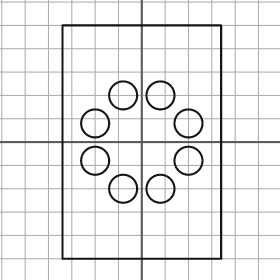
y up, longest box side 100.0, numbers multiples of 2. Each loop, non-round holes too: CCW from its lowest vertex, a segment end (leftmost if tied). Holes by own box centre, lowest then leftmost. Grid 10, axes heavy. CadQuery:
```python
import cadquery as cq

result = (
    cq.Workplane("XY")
    .moveTo(-34.0, -50.0)
    .lineTo(34.0, -50.0)
    .lineTo(34.0, 50.0)
    .lineTo(-34.0, 50.0)
    .close()
    .moveTo(-8.0, -20.0)
    .circle(6.0)
    .moveTo(8.0, -20.0)
    .circle(6.0)
    .moveTo(-20.0, -8.0)
    .circle(6.0)
    .moveTo(20.0, -8.0)
    .circle(6.0)
    .moveTo(-20.0, 8.0)
    .circle(6.0)
    .moveTo(20.0, 8.0)
    .circle(6.0)
    .moveTo(-8.0, 20.0)
    .circle(6.0)
    .moveTo(8.0, 20.0)
    .circle(6.0)
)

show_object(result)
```